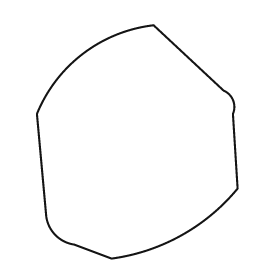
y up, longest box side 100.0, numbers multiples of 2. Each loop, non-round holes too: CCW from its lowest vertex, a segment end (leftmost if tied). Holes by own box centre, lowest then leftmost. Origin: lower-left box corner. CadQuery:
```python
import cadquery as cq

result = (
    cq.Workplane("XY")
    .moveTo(32.0, 0.0)
    .threePointArc((62.0, 10.0), (86.0, 30.0))
    .lineTo(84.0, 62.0)
    .threePointArc((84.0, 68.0), (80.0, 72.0))
    .lineTo(50.0, 100.0)
    .threePointArc((20.0, 88.0), (0.0, 62.0))
    .lineTo(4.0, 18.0)
    .threePointArc((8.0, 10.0), (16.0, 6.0))
    .close()
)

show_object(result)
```